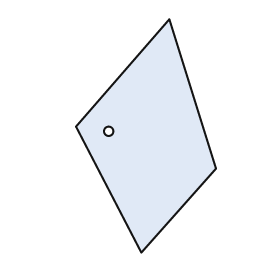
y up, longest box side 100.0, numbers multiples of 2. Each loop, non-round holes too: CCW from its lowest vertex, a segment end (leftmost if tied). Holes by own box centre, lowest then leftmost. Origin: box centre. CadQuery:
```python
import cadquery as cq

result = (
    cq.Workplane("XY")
    .moveTo(-2.0, -50.0)
    .lineTo(30.0, -14.0)
    .lineTo(10.0, 50.0)
    .lineTo(-30.0, 4.0)
    .close()
    .moveTo(-16.0, 2.0)
    .circle(2.0)
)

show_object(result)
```